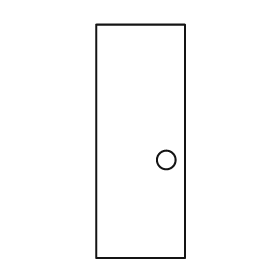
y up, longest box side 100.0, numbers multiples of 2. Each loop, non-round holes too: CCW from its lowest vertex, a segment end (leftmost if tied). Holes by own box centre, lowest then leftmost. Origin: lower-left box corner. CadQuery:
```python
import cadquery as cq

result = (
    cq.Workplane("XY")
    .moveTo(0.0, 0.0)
    .lineTo(38.0, 0.0)
    .lineTo(38.0, 100.0)
    .lineTo(0.0, 100.0)
    .close()
    .moveTo(30.0, 42.0)
    .circle(4.0)
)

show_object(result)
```